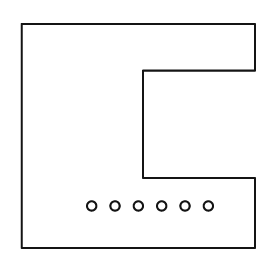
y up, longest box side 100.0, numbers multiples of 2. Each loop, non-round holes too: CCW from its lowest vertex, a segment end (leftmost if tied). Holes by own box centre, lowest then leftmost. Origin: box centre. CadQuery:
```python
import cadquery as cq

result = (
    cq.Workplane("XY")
    .moveTo(-50.0, -48.0)
    .lineTo(50.0, -48.0)
    .lineTo(50.0, -18.0)
    .lineTo(2.0, -18.0)
    .lineTo(2.0, 28.0)
    .lineTo(50.0, 28.0)
    .lineTo(50.0, 48.0)
    .lineTo(-50.0, 48.0)
    .close()
    .moveTo(-20.0, -30.0)
    .circle(2.0)
    .moveTo(-10.0, -30.0)
    .circle(2.0)
    .moveTo(0.0, -30.0)
    .circle(2.0)
    .moveTo(10.0, -30.0)
    .circle(2.0)
    .moveTo(20.0, -30.0)
    .circle(2.0)
    .moveTo(30.0, -30.0)
    .circle(2.0)
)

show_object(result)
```